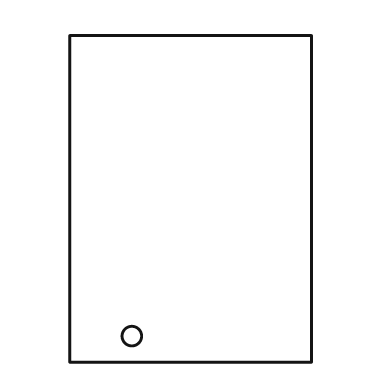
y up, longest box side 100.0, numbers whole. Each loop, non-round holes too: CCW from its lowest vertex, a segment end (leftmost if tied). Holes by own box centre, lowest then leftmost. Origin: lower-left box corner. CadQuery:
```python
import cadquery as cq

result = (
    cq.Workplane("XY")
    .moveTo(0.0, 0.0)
    .lineTo(74.0, 0.0)
    .lineTo(74.0, 100.0)
    .lineTo(0.0, 100.0)
    .close()
    .moveTo(19.0, 8.0)
    .circle(3.0)
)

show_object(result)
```